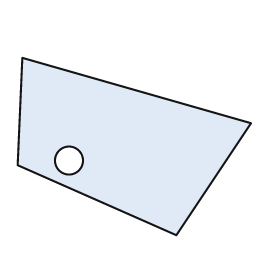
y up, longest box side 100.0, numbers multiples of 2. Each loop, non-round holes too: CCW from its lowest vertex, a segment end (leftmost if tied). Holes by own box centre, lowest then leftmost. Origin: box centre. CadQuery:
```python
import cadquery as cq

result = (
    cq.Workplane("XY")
    .moveTo(18.0, -38.0)
    .lineTo(50.0, 10.0)
    .lineTo(-48.0, 38.0)
    .lineTo(-50.0, -8.0)
    .close()
    .moveTo(-28.0, -6.0)
    .circle(6.0)
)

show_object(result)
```